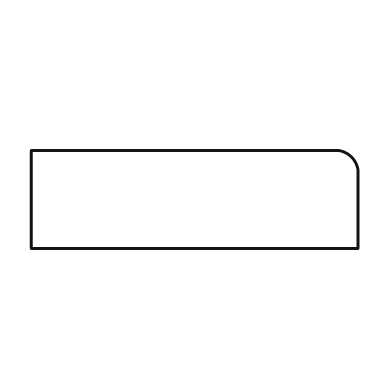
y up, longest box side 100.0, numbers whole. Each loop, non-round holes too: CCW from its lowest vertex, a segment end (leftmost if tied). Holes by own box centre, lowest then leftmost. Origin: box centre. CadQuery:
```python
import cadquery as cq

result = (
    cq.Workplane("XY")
    .moveTo(-50.0, -15.0)
    .lineTo(50.0, -15.0)
    .lineTo(50.0, 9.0)
    .threePointArc((48.0, 13.0), (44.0, 15.0))
    .lineTo(-50.0, 15.0)
    .close()
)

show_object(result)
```